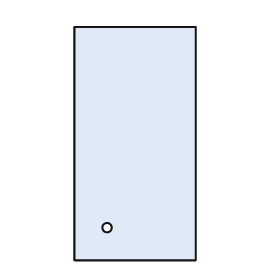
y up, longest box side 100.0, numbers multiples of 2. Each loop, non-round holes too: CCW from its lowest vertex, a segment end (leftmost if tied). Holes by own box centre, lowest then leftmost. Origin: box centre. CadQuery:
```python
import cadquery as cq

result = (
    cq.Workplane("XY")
    .moveTo(-26.0, -50.0)
    .lineTo(26.0, -50.0)
    .lineTo(26.0, 50.0)
    .lineTo(-26.0, 50.0)
    .close()
    .moveTo(-12.0, -36.0)
    .circle(2.0)
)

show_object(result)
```